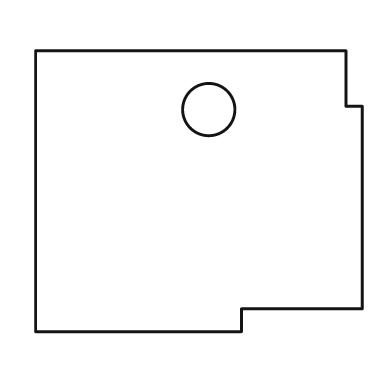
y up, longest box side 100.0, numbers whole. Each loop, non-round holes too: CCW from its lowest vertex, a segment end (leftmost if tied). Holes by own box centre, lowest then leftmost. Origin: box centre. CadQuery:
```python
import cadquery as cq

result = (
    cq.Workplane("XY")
    .moveTo(-50.0, -43.0)
    .lineTo(13.0, -43.0)
    .lineTo(13.0, -36.0)
    .lineTo(50.0, -36.0)
    .lineTo(50.0, 26.0)
    .lineTo(45.0, 26.0)
    .lineTo(45.0, 43.0)
    .lineTo(-50.0, 43.0)
    .close()
    .moveTo(3.0, 25.0)
    .circle(8.0)
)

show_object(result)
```